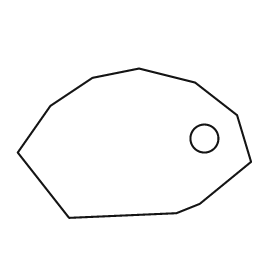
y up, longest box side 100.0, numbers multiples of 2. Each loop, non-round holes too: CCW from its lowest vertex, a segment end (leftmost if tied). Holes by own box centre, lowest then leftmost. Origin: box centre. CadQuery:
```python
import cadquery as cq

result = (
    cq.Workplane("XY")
    .moveTo(-28.0, -32.0)
    .lineTo(18.0, -30.0)
    .lineTo(28.0, -26.0)
    .lineTo(50.0, -8.0)
    .lineTo(44.0, 12.0)
    .lineTo(26.0, 26.0)
    .lineTo(2.0, 32.0)
    .lineTo(-18.0, 28.0)
    .lineTo(-36.0, 16.0)
    .lineTo(-50.0, -4.0)
    .close()
    .moveTo(30.0, 2.0)
    .circle(6.0)
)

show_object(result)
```